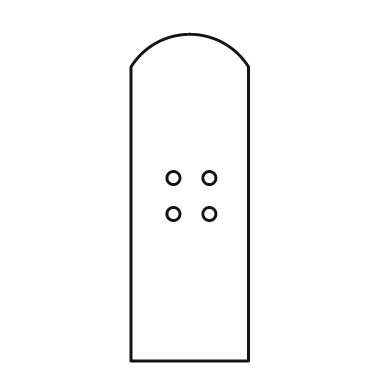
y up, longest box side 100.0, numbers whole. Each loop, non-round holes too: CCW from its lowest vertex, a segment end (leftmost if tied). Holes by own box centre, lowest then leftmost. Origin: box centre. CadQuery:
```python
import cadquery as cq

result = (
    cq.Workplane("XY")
    .moveTo(-18.0, -50.0)
    .lineTo(18.0, -50.0)
    .lineTo(18.0, 40.0)
    .threePointArc((0.0, 50.0), (-18.0, 40.0))
    .close()
    .moveTo(-5.0, -5.0)
    .circle(2.0)
    .moveTo(6.0, -5.0)
    .circle(2.0)
    .moveTo(-5.0, 6.0)
    .circle(2.0)
    .moveTo(6.0, 6.0)
    .circle(2.0)
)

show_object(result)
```